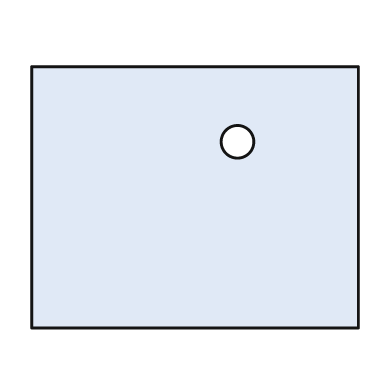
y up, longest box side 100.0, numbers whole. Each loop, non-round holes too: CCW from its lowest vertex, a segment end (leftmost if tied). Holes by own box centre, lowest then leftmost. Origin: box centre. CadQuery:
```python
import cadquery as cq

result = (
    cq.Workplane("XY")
    .moveTo(-50.0, -40.0)
    .lineTo(50.0, -40.0)
    .lineTo(50.0, 40.0)
    .lineTo(-50.0, 40.0)
    .close()
    .moveTo(13.0, 17.0)
    .circle(5.0)
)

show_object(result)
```